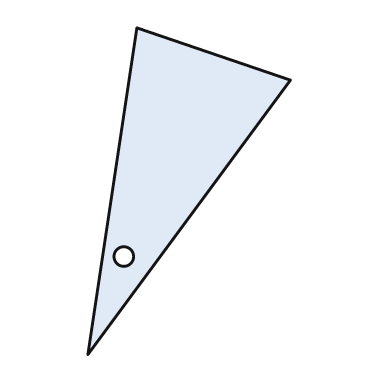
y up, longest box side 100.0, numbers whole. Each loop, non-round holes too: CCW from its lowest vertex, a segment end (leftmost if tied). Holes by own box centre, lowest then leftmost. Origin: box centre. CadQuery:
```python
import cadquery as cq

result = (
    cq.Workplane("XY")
    .moveTo(-31.0, -50.0)
    .lineTo(31.0, 34.0)
    .lineTo(-16.0, 50.0)
    .close()
    .moveTo(-20.0, -20.0)
    .circle(3.0)
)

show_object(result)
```